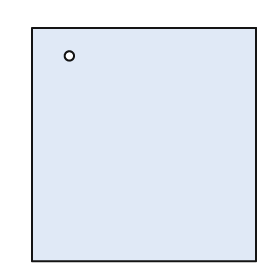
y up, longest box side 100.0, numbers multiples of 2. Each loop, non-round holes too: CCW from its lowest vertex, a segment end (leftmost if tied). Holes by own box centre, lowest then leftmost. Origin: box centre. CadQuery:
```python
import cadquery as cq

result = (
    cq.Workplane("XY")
    .moveTo(-48.0, -50.0)
    .lineTo(48.0, -50.0)
    .lineTo(48.0, 50.0)
    .lineTo(-48.0, 50.0)
    .close()
    .moveTo(-32.0, 38.0)
    .circle(2.0)
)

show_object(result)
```